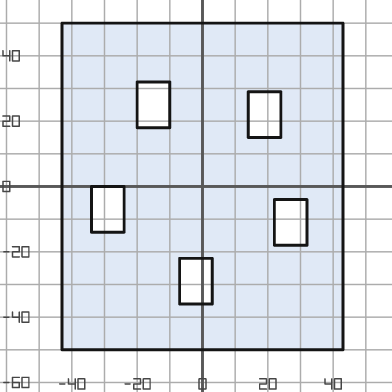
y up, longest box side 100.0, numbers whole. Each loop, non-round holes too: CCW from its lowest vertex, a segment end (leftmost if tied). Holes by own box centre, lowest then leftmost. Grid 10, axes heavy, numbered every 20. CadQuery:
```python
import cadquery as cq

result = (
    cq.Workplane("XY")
    .moveTo(-43.0, -50.0)
    .lineTo(43.0, -50.0)
    .lineTo(43.0, 50.0)
    .lineTo(-43.0, 50.0)
    .close()
    .moveTo(-7.0, -36.0)
    .lineTo(3.0, -36.0)
    .lineTo(3.0, -22.0)
    .lineTo(-7.0, -22.0)
    .close()
    .moveTo(22.0, -18.0)
    .lineTo(32.0, -18.0)
    .lineTo(32.0, -4.0)
    .lineTo(22.0, -4.0)
    .close()
    .moveTo(-34.0, -14.0)
    .lineTo(-24.0, -14.0)
    .lineTo(-24.0, 0.0)
    .lineTo(-34.0, 0.0)
    .close()
    .moveTo(14.0, 15.0)
    .lineTo(24.0, 15.0)
    .lineTo(24.0, 29.0)
    .lineTo(14.0, 29.0)
    .close()
    .moveTo(-20.0, 18.0)
    .lineTo(-10.0, 18.0)
    .lineTo(-10.0, 32.0)
    .lineTo(-20.0, 32.0)
    .close()
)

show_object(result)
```